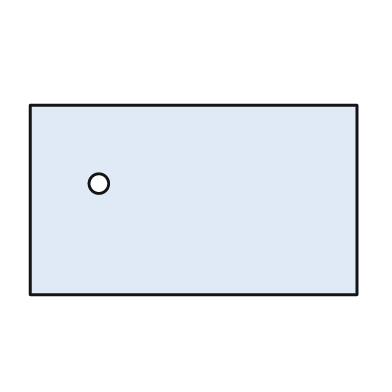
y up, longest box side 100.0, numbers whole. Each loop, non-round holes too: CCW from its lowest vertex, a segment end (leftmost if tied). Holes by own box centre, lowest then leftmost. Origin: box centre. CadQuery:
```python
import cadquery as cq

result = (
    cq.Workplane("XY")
    .moveTo(-50.0, -29.0)
    .lineTo(50.0, -29.0)
    .lineTo(50.0, 29.0)
    .lineTo(-50.0, 29.0)
    .close()
    .moveTo(-29.0, 5.0)
    .circle(3.0)
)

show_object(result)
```